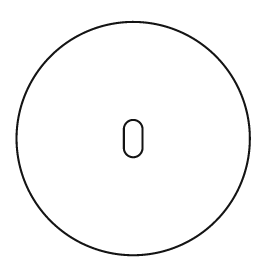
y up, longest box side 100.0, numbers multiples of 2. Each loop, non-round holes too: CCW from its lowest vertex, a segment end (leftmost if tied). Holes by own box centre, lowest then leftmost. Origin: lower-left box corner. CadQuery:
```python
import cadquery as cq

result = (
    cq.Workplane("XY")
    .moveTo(50.0, 50.0)
    .circle(50.0)
    .moveTo(46.0, 46.0)
    .threePointArc((50.0, 42.0), (54.0, 46.0))
    .lineTo(54.0, 54.0)
    .threePointArc((50.0, 58.0), (46.0, 54.0))
    .close()
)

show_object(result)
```